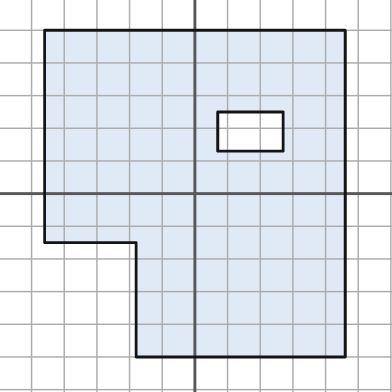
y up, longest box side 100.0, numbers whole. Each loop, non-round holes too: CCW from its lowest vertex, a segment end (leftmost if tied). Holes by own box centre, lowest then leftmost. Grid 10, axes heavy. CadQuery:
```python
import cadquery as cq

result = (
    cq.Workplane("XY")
    .moveTo(-18.0, -50.0)
    .lineTo(46.0, -50.0)
    .lineTo(46.0, 50.0)
    .lineTo(-46.0, 50.0)
    .lineTo(-46.0, -15.0)
    .lineTo(-18.0, -15.0)
    .close()
    .moveTo(7.0, 13.0)
    .lineTo(27.0, 13.0)
    .lineTo(27.0, 25.0)
    .lineTo(7.0, 25.0)
    .close()
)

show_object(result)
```